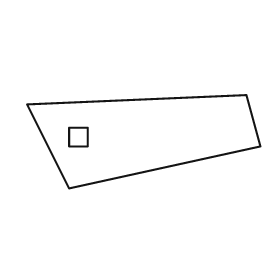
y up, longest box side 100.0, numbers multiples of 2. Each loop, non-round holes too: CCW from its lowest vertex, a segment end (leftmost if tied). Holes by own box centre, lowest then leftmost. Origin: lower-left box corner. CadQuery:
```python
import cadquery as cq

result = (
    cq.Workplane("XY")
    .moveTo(18.0, 0.0)
    .lineTo(100.0, 18.0)
    .lineTo(94.0, 40.0)
    .lineTo(0.0, 36.0)
    .close()
    .moveTo(18.0, 18.0)
    .lineTo(26.0, 18.0)
    .lineTo(26.0, 26.0)
    .lineTo(18.0, 26.0)
    .close()
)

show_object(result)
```